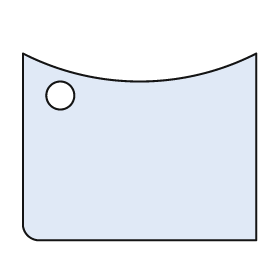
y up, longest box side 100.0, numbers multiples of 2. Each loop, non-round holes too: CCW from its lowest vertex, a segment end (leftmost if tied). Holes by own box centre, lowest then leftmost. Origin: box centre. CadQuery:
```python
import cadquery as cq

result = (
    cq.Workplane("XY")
    .moveTo(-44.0, -40.0)
    .lineTo(50.0, -40.0)
    .lineTo(50.0, 40.0)
    .threePointArc((0.0, 28.0), (-50.0, 40.0))
    .lineTo(-50.0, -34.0)
    .threePointArc((-48.0, -38.0), (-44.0, -40.0))
    .close()
    .moveTo(-34.0, 22.0)
    .circle(6.0)
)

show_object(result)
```